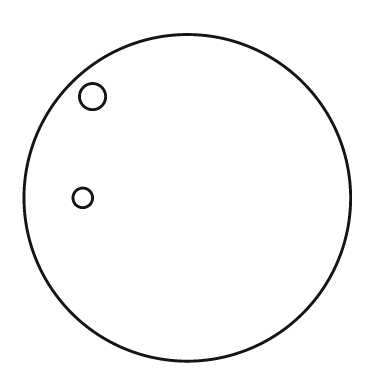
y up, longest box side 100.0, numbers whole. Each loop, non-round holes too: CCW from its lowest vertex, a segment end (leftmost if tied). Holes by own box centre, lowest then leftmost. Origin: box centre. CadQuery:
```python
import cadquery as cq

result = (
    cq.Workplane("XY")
    .moveTo(0.0, 0.0)
    .circle(50.0)
    .moveTo(-32.0, 0.0)
    .circle(3.0)
    .moveTo(-29.0, 31.0)
    .circle(4.0)
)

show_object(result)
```